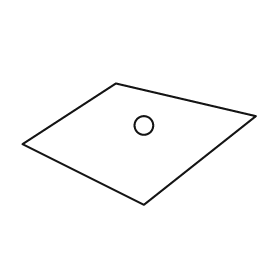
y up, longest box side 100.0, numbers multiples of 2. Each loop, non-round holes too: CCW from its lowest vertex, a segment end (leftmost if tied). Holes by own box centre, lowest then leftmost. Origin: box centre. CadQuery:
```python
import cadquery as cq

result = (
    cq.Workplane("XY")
    .moveTo(2.0, -26.0)
    .lineTo(50.0, 12.0)
    .lineTo(-10.0, 26.0)
    .lineTo(-50.0, 0.0)
    .close()
    .moveTo(2.0, 8.0)
    .circle(4.0)
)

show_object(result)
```